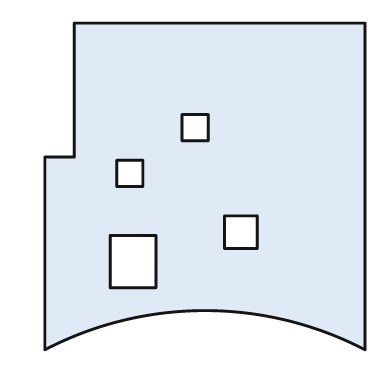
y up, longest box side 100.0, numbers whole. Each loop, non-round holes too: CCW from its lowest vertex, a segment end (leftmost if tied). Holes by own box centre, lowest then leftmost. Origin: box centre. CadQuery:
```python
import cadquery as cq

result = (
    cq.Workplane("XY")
    .moveTo(-49.0, -50.0)
    .threePointArc((0.0, -38.0), (49.0, -50.0))
    .lineTo(49.0, 50.0)
    .lineTo(-40.0, 50.0)
    .lineTo(-40.0, 9.0)
    .lineTo(-49.0, 9.0)
    .close()
    .moveTo(-29.0, -31.0)
    .lineTo(-15.0, -31.0)
    .lineTo(-15.0, -15.0)
    .lineTo(-29.0, -15.0)
    .close()
    .moveTo(6.0, -19.0)
    .lineTo(16.0, -19.0)
    .lineTo(16.0, -9.0)
    .lineTo(6.0, -9.0)
    .close()
    .moveTo(-27.0, 0.0)
    .lineTo(-19.0, 0.0)
    .lineTo(-19.0, 8.0)
    .lineTo(-27.0, 8.0)
    .close()
    .moveTo(-7.0, 14.0)
    .lineTo(1.0, 14.0)
    .lineTo(1.0, 22.0)
    .lineTo(-7.0, 22.0)
    .close()
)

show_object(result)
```